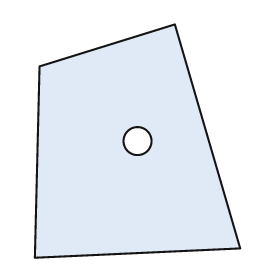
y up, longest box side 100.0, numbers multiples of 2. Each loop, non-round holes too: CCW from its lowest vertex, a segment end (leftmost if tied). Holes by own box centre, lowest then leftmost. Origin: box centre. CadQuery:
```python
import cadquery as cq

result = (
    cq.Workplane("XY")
    .moveTo(-44.0, -50.0)
    .lineTo(44.0, -46.0)
    .lineTo(16.0, 50.0)
    .lineTo(-42.0, 32.0)
    .close()
    .moveTo(0.0, 0.0)
    .circle(6.0)
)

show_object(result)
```